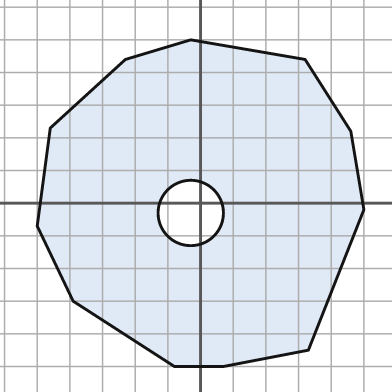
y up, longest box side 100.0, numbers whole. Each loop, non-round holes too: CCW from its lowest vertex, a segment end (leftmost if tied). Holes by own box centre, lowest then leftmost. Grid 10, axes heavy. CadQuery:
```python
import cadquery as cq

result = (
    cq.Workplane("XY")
    .moveTo(-8.0, -50.0)
    .lineTo(7.0, -50.0)
    .lineTo(33.0, -45.0)
    .lineTo(50.0, -2.0)
    .lineTo(46.0, 22.0)
    .lineTo(32.0, 44.0)
    .lineTo(-3.0, 50.0)
    .lineTo(-23.0, 44.0)
    .lineTo(-46.0, 23.0)
    .lineTo(-50.0, -7.0)
    .lineTo(-39.0, -30.0)
    .close()
    .moveTo(-3.0, -3.0)
    .circle(10.0)
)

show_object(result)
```